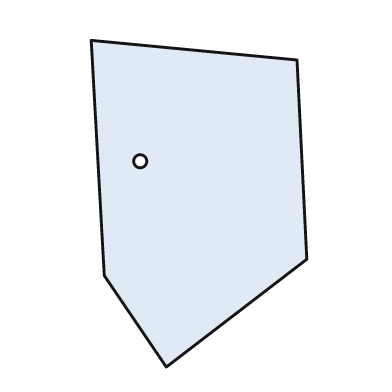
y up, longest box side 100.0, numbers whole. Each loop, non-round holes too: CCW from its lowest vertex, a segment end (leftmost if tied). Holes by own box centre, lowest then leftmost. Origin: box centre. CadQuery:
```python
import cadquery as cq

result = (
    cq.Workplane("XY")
    .moveTo(-10.0, -50.0)
    .lineTo(33.0, -17.0)
    .lineTo(30.0, 44.0)
    .lineTo(-33.0, 50.0)
    .lineTo(-29.0, -22.0)
    .close()
    .moveTo(-18.0, 13.0)
    .circle(2.0)
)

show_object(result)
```